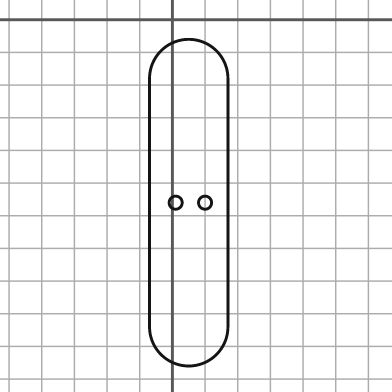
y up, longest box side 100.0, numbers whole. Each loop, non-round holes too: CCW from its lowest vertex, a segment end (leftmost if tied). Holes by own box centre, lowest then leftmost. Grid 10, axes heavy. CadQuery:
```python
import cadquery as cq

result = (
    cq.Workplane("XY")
    .moveTo(-7.0, -94.0)
    .threePointArc((5.0, -106.0), (17.0, -94.0))
    .lineTo(17.0, -18.0)
    .threePointArc((5.0, -6.0), (-7.0, -18.0))
    .close()
    .moveTo(1.0, -56.0)
    .circle(2.0)
    .moveTo(10.0, -56.0)
    .circle(2.0)
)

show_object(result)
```